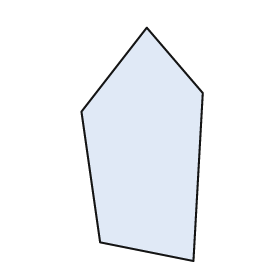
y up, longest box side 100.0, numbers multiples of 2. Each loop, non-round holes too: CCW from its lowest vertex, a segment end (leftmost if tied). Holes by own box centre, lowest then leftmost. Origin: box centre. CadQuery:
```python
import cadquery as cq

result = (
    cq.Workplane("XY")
    .moveTo(22.0, -50.0)
    .lineTo(26.0, 22.0)
    .lineTo(2.0, 50.0)
    .lineTo(-26.0, 14.0)
    .lineTo(-18.0, -42.0)
    .close()
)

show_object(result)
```